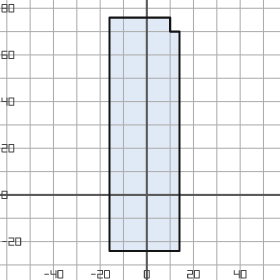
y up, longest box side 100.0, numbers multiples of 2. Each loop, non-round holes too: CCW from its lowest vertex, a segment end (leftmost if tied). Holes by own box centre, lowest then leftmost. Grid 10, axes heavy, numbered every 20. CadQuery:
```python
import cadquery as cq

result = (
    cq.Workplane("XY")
    .moveTo(-16.0, -24.0)
    .lineTo(14.0, -24.0)
    .lineTo(14.0, 70.0)
    .lineTo(10.0, 70.0)
    .lineTo(10.0, 76.0)
    .lineTo(-16.0, 76.0)
    .close()
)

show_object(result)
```